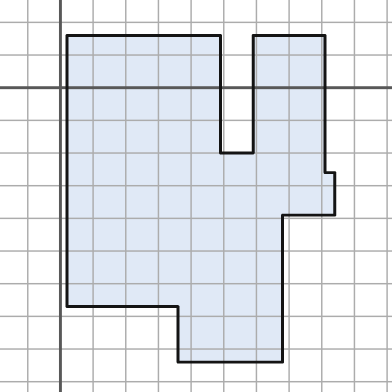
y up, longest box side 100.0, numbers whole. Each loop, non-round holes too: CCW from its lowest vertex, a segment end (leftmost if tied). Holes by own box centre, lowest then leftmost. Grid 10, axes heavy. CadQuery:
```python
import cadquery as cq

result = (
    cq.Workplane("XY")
    .moveTo(36.0, -84.0)
    .lineTo(68.0, -84.0)
    .lineTo(68.0, -39.0)
    .lineTo(84.0, -39.0)
    .lineTo(84.0, -26.0)
    .lineTo(81.0, -26.0)
    .lineTo(81.0, 16.0)
    .lineTo(59.0, 16.0)
    .lineTo(59.0, -20.0)
    .lineTo(49.0, -20.0)
    .lineTo(49.0, 16.0)
    .lineTo(2.0, 16.0)
    .lineTo(2.0, -67.0)
    .lineTo(36.0, -67.0)
    .close()
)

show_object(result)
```